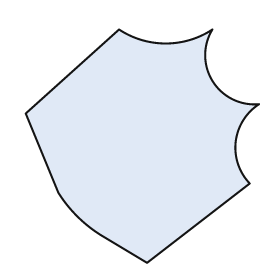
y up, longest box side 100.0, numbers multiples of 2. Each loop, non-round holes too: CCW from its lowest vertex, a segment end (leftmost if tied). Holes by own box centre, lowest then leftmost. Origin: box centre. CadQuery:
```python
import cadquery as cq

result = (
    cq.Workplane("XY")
    .moveTo(2.0, -50.0)
    .lineTo(46.0, -16.0)
    .threePointArc((40.0, 2.0), (50.0, 18.0))
    .threePointArc((30.0, 28.0), (30.0, 50.0))
    .threePointArc((10.0, 44.0), (-10.0, 50.0))
    .lineTo(-50.0, 14.0)
    .lineTo(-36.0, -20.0)
    .threePointArc((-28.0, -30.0), (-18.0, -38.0))
    .close()
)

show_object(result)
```